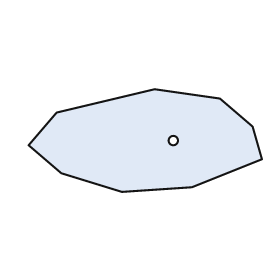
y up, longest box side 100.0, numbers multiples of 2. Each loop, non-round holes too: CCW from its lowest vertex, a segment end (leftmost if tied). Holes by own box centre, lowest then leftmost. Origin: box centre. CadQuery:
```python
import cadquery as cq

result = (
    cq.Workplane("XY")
    .moveTo(-10.0, -22.0)
    .lineTo(20.0, -20.0)
    .lineTo(50.0, -8.0)
    .lineTo(46.0, 6.0)
    .lineTo(32.0, 18.0)
    .lineTo(4.0, 22.0)
    .lineTo(-38.0, 12.0)
    .lineTo(-50.0, -2.0)
    .lineTo(-36.0, -14.0)
    .close()
    .moveTo(12.0, 0.0)
    .circle(2.0)
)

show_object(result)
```